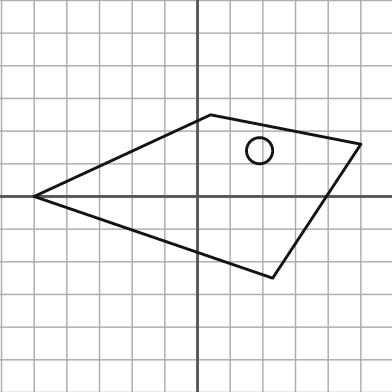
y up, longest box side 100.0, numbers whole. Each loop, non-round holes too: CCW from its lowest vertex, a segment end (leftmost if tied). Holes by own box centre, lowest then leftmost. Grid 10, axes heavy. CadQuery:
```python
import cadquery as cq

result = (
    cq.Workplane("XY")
    .moveTo(23.0, -25.0)
    .lineTo(50.0, 16.0)
    .lineTo(4.0, 25.0)
    .lineTo(-50.0, 0.0)
    .close()
    .moveTo(19.0, 14.0)
    .circle(4.0)
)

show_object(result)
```